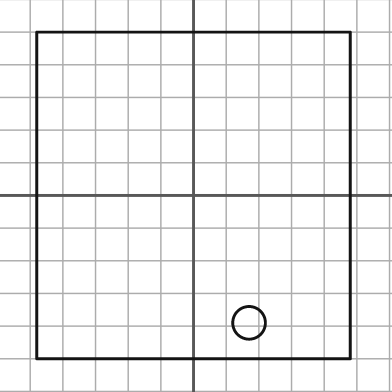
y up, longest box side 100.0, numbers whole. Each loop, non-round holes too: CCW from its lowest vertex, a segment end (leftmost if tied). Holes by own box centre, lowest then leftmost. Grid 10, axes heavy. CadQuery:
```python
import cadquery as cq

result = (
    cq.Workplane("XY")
    .moveTo(-48.0, -50.0)
    .lineTo(48.0, -50.0)
    .lineTo(48.0, 50.0)
    .lineTo(-48.0, 50.0)
    .close()
    .moveTo(17.0, -39.0)
    .circle(5.0)
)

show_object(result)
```